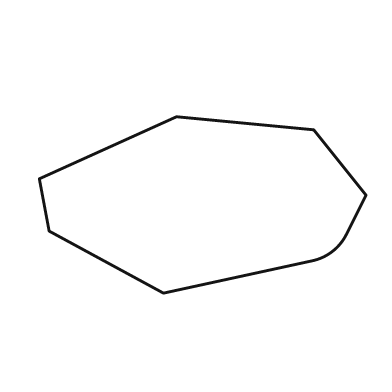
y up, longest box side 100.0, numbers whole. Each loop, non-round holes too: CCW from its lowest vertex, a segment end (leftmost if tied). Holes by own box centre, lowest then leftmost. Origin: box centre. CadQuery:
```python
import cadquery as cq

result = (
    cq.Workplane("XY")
    .moveTo(-12.0, -27.0)
    .lineTo(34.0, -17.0)
    .threePointArc((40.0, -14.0), (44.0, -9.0))
    .lineTo(50.0, 3.0)
    .lineTo(34.0, 23.0)
    .lineTo(-8.0, 27.0)
    .lineTo(-50.0, 8.0)
    .lineTo(-47.0, -8.0)
    .close()
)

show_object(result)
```